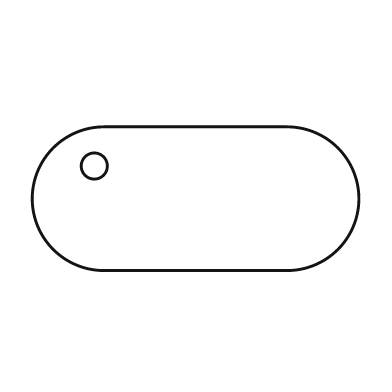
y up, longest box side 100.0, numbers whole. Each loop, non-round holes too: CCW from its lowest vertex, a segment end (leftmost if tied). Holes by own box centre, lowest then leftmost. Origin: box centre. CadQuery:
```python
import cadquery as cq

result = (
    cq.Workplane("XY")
    .moveTo(-28.0, -22.0)
    .lineTo(28.0, -22.0)
    .threePointArc((50.0, 0.0), (28.0, 22.0))
    .lineTo(-28.0, 22.0)
    .threePointArc((-50.0, 0.0), (-28.0, -22.0))
    .close()
    .moveTo(-31.0, 10.0)
    .circle(4.0)
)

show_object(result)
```